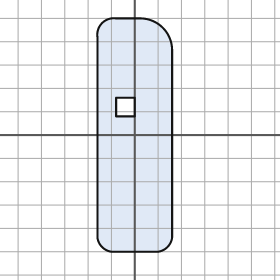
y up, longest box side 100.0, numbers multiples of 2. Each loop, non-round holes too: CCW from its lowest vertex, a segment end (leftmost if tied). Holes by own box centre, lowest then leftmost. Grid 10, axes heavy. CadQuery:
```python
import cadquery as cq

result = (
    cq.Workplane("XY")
    .moveTo(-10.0, -50.0)
    .lineTo(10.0, -50.0)
    .threePointArc((14.0, -48.0), (16.0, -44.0))
    .lineTo(16.0, 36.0)
    .threePointArc((12.0, 46.0), (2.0, 50.0))
    .lineTo(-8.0, 50.0)
    .threePointArc((-14.0, 48.0), (-16.0, 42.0))
    .lineTo(-16.0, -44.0)
    .threePointArc((-14.0, -48.0), (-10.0, -50.0))
    .close()
    .moveTo(-8.0, 8.0)
    .lineTo(0.0, 8.0)
    .lineTo(0.0, 16.0)
    .lineTo(-8.0, 16.0)
    .close()
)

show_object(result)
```